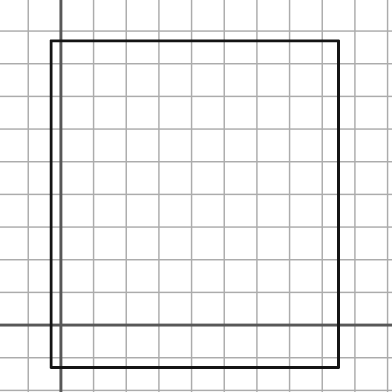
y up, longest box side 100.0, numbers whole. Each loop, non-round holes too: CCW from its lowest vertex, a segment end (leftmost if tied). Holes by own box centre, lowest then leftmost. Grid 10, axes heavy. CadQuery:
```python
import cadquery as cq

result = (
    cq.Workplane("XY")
    .moveTo(-3.0, -13.0)
    .lineTo(85.0, -13.0)
    .lineTo(85.0, 87.0)
    .lineTo(-3.0, 87.0)
    .close()
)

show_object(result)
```